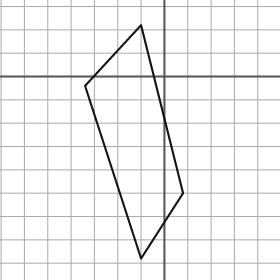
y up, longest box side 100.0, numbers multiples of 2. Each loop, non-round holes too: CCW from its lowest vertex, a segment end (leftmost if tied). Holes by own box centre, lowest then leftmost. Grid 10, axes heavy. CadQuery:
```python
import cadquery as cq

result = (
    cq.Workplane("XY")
    .moveTo(-10.0, -78.0)
    .lineTo(8.0, -50.0)
    .lineTo(-10.0, 22.0)
    .lineTo(-34.0, -4.0)
    .close()
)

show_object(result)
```